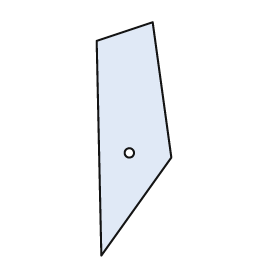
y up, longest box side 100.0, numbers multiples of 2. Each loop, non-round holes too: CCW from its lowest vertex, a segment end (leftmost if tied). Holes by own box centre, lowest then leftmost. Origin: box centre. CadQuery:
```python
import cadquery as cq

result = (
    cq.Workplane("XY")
    .moveTo(-14.0, -50.0)
    .lineTo(16.0, -8.0)
    .lineTo(8.0, 50.0)
    .lineTo(-16.0, 42.0)
    .close()
    .moveTo(-2.0, -6.0)
    .circle(2.0)
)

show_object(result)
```